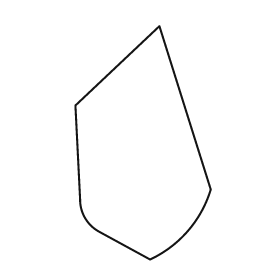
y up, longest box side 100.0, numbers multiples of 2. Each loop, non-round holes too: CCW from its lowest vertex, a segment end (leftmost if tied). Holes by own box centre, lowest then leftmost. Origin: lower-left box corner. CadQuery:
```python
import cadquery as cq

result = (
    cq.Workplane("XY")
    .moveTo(32.0, 0.0)
    .threePointArc((48.0, 12.0), (58.0, 30.0))
    .lineTo(36.0, 100.0)
    .lineTo(0.0, 66.0)
    .lineTo(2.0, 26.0)
    .threePointArc((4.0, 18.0), (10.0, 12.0))
    .close()
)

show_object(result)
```